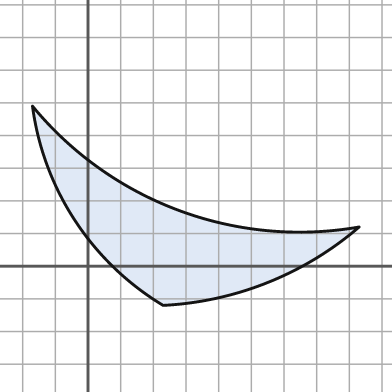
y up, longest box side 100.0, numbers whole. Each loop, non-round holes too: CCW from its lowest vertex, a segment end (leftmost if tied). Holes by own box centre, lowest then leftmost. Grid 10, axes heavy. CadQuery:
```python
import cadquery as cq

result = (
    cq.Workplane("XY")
    .moveTo(23.0, -12.0)
    .threePointArc((55.0, -5.0), (83.0, 12.0))
    .threePointArc((28.0, 17.0), (-17.0, 49.0))
    .threePointArc((-4.0, 14.0), (23.0, -12.0))
    .close()
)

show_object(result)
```